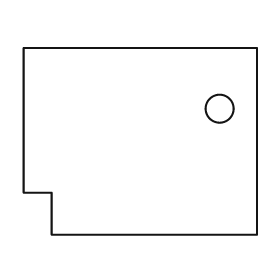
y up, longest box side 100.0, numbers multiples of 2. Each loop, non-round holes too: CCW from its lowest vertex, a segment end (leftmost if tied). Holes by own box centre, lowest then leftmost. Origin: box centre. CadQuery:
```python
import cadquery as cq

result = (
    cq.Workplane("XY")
    .moveTo(-38.0, -40.0)
    .lineTo(50.0, -40.0)
    .lineTo(50.0, 40.0)
    .lineTo(-50.0, 40.0)
    .lineTo(-50.0, -22.0)
    .lineTo(-38.0, -22.0)
    .close()
    .moveTo(34.0, 14.0)
    .circle(6.0)
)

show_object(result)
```